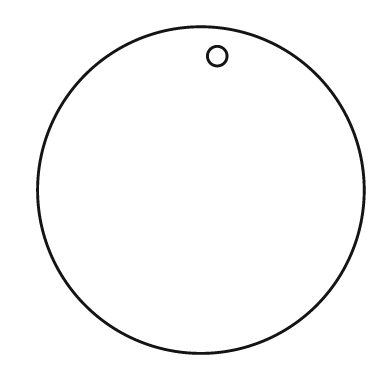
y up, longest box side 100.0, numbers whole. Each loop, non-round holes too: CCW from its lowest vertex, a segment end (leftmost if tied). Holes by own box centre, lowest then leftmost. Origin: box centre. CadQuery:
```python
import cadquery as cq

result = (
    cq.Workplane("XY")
    .moveTo(0.0, 0.0)
    .circle(50.0)
    .moveTo(5.0, 41.0)
    .circle(3.0)
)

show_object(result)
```